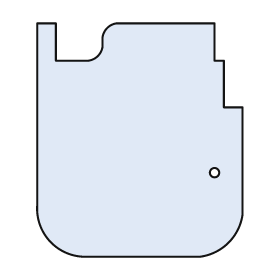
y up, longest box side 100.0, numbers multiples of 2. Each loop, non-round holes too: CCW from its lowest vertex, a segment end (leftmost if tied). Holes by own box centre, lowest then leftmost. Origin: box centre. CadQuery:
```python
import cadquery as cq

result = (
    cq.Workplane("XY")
    .moveTo(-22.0, -50.0)
    .lineTo(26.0, -50.0)
    .threePointArc((38.0, -44.0), (44.0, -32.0))
    .lineTo(44.0, 14.0)
    .lineTo(36.0, 14.0)
    .lineTo(36.0, 34.0)
    .lineTo(32.0, 34.0)
    .lineTo(32.0, 50.0)
    .lineTo(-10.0, 50.0)
    .threePointArc((-14.0, 48.0), (-16.0, 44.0))
    .lineTo(-16.0, 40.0)
    .threePointArc((-18.0, 36.0), (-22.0, 34.0))
    .lineTo(-36.0, 34.0)
    .lineTo(-36.0, 50.0)
    .lineTo(-44.0, 50.0)
    .lineTo(-44.0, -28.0)
    .threePointArc((-38.0, -44.0), (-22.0, -50.0))
    .close()
    .moveTo(32.0, -14.0)
    .circle(2.0)
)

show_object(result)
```